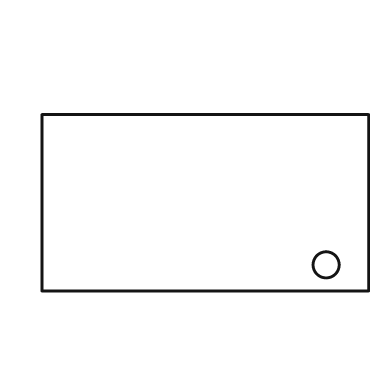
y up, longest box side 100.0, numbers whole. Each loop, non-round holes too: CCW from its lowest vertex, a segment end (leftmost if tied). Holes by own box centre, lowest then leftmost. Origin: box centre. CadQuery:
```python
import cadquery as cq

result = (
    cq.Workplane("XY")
    .moveTo(-50.0, -27.0)
    .lineTo(50.0, -27.0)
    .lineTo(50.0, 27.0)
    .lineTo(-50.0, 27.0)
    .close()
    .moveTo(37.0, -19.0)
    .circle(4.0)
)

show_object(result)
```